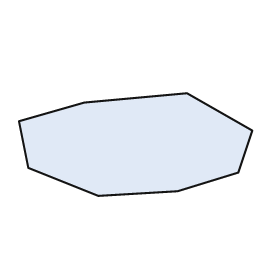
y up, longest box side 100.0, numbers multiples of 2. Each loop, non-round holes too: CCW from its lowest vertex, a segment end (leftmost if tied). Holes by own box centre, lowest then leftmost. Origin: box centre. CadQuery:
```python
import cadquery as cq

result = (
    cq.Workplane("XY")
    .moveTo(-16.0, -22.0)
    .lineTo(18.0, -20.0)
    .lineTo(44.0, -12.0)
    .lineTo(50.0, 6.0)
    .lineTo(22.0, 22.0)
    .lineTo(-22.0, 18.0)
    .lineTo(-50.0, 10.0)
    .lineTo(-46.0, -10.0)
    .close()
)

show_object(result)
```